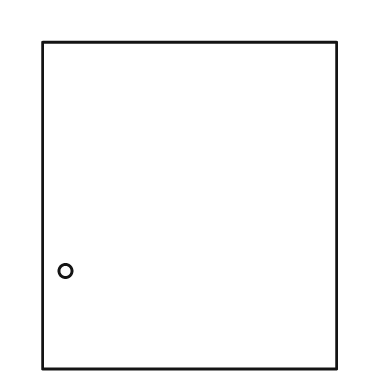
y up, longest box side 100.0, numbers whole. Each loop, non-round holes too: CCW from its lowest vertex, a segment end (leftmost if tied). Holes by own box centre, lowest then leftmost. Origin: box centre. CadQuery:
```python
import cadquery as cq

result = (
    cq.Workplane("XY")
    .moveTo(-45.0, -50.0)
    .lineTo(45.0, -50.0)
    .lineTo(45.0, 50.0)
    .lineTo(-45.0, 50.0)
    .close()
    .moveTo(-38.0, -20.0)
    .circle(2.0)
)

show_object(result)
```